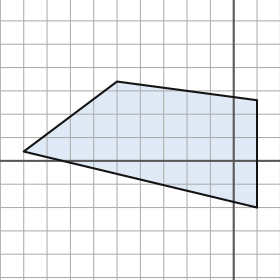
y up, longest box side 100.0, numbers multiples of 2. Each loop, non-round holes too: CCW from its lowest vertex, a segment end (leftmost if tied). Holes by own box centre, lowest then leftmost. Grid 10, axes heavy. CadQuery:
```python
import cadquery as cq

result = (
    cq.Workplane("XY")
    .moveTo(10.0, -20.0)
    .lineTo(10.0, 26.0)
    .lineTo(-50.0, 34.0)
    .lineTo(-90.0, 4.0)
    .close()
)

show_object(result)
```